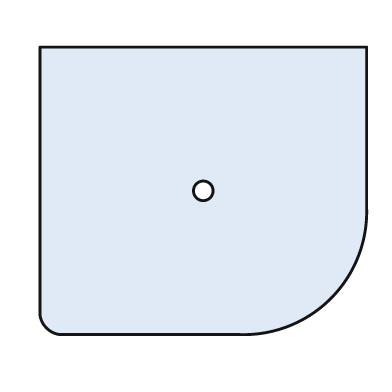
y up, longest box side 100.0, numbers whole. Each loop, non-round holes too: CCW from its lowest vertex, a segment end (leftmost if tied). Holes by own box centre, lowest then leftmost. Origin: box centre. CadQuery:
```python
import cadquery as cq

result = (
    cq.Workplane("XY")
    .moveTo(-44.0, -44.0)
    .lineTo(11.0, -44.0)
    .threePointArc((39.0, -33.0), (50.0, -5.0))
    .lineTo(50.0, 44.0)
    .lineTo(-50.0, 44.0)
    .lineTo(-50.0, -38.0)
    .threePointArc((-48.0, -42.0), (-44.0, -44.0))
    .close()
    .moveTo(0.0, 0.0)
    .circle(3.0)
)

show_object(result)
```